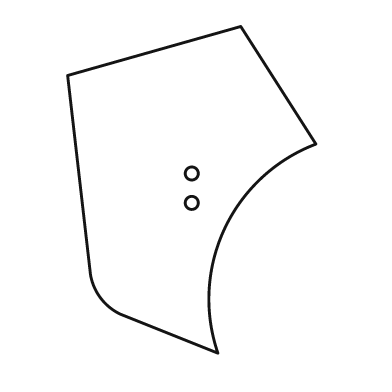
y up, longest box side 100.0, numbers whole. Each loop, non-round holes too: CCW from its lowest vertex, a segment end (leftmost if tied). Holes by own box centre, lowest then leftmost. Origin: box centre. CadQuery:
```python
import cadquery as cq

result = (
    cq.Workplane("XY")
    .moveTo(8.0, -50.0)
    .threePointArc((10.0, -12.0), (38.0, 14.0))
    .lineTo(15.0, 50.0)
    .lineTo(-38.0, 35.0)
    .lineTo(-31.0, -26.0)
    .threePointArc((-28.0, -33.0), (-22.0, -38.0))
    .close()
    .moveTo(0.0, -4.0)
    .circle(2.0)
    .moveTo(0.0, 5.0)
    .circle(2.0)
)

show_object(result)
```